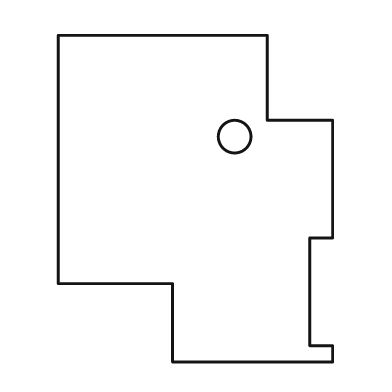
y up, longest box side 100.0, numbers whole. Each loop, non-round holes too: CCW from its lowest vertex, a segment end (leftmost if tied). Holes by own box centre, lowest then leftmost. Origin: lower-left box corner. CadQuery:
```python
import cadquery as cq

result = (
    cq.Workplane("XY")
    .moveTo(35.0, 0.0)
    .lineTo(84.0, 0.0)
    .lineTo(84.0, 5.0)
    .lineTo(77.0, 5.0)
    .lineTo(77.0, 38.0)
    .lineTo(84.0, 38.0)
    .lineTo(84.0, 74.0)
    .lineTo(64.0, 74.0)
    .lineTo(64.0, 100.0)
    .lineTo(0.0, 100.0)
    .lineTo(0.0, 24.0)
    .lineTo(35.0, 24.0)
    .close()
    .moveTo(54.0, 69.0)
    .circle(5.0)
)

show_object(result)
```